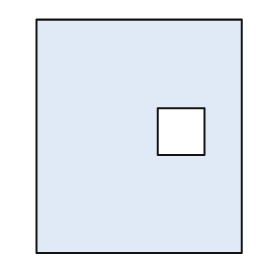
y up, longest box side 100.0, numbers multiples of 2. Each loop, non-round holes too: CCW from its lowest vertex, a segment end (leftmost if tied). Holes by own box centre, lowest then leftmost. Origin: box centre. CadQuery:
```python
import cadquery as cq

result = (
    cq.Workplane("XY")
    .moveTo(-44.0, -50.0)
    .lineTo(44.0, -50.0)
    .lineTo(44.0, 50.0)
    .lineTo(-44.0, 50.0)
    .close()
    .moveTo(8.0, -8.0)
    .lineTo(28.0, -8.0)
    .lineTo(28.0, 12.0)
    .lineTo(8.0, 12.0)
    .close()
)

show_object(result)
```